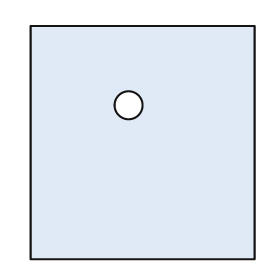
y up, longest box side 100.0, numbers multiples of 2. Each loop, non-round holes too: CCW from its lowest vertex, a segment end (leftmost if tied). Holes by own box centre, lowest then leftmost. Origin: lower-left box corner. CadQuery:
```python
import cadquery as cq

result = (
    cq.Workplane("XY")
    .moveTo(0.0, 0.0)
    .lineTo(96.0, 0.0)
    .lineTo(96.0, 100.0)
    .lineTo(0.0, 100.0)
    .close()
    .moveTo(42.0, 66.0)
    .circle(6.0)
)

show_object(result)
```